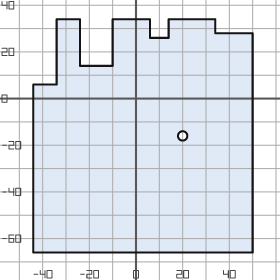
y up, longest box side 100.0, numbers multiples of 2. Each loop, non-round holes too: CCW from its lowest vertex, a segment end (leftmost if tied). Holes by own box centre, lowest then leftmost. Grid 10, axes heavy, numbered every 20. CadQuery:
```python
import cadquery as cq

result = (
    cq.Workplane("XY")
    .moveTo(-44.0, -66.0)
    .lineTo(50.0, -66.0)
    .lineTo(50.0, 28.0)
    .lineTo(34.0, 28.0)
    .lineTo(34.0, 34.0)
    .lineTo(14.0, 34.0)
    .lineTo(14.0, 26.0)
    .lineTo(6.0, 26.0)
    .lineTo(6.0, 34.0)
    .lineTo(-10.0, 34.0)
    .lineTo(-10.0, 14.0)
    .lineTo(-24.0, 14.0)
    .lineTo(-24.0, 34.0)
    .lineTo(-34.0, 34.0)
    .lineTo(-34.0, 6.0)
    .lineTo(-44.0, 6.0)
    .close()
    .moveTo(20.0, -16.0)
    .circle(2.0)
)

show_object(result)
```